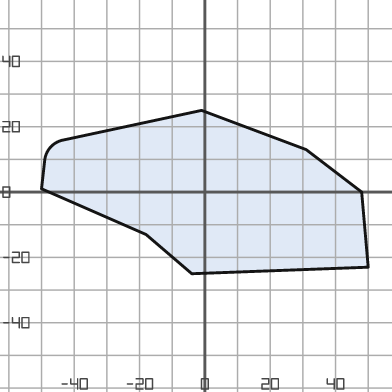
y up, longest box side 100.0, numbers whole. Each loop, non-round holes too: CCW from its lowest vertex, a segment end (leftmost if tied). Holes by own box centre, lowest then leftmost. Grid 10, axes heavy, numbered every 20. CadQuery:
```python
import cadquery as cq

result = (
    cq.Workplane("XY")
    .moveTo(-4.0, -25.0)
    .lineTo(50.0, -23.0)
    .lineTo(48.0, 0.0)
    .lineTo(31.0, 13.0)
    .lineTo(-1.0, 25.0)
    .lineTo(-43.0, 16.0)
    .threePointArc((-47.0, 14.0), (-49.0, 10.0))
    .lineTo(-50.0, 1.0)
    .lineTo(-18.0, -13.0)
    .close()
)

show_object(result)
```